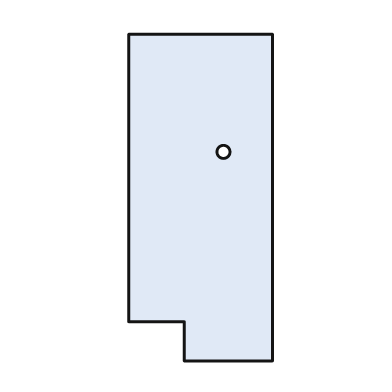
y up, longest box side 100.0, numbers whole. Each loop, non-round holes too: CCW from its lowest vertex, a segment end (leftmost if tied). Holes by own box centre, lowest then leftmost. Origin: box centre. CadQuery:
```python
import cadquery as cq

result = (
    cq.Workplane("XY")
    .moveTo(-5.0, -50.0)
    .lineTo(22.0, -50.0)
    .lineTo(22.0, 50.0)
    .lineTo(-22.0, 50.0)
    .lineTo(-22.0, -38.0)
    .lineTo(-5.0, -38.0)
    .close()
    .moveTo(7.0, 14.0)
    .circle(2.0)
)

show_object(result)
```